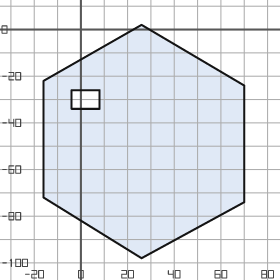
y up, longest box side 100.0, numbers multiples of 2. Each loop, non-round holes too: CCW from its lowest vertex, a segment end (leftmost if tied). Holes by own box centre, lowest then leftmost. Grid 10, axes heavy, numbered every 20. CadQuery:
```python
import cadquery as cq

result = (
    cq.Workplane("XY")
    .moveTo(26.0, -98.0)
    .lineTo(70.0, -74.0)
    .lineTo(70.0, -24.0)
    .lineTo(26.0, 2.0)
    .lineTo(-16.0, -22.0)
    .lineTo(-16.0, -72.0)
    .close()
    .moveTo(-4.0, -34.0)
    .lineTo(8.0, -34.0)
    .lineTo(8.0, -26.0)
    .lineTo(-4.0, -26.0)
    .close()
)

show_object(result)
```